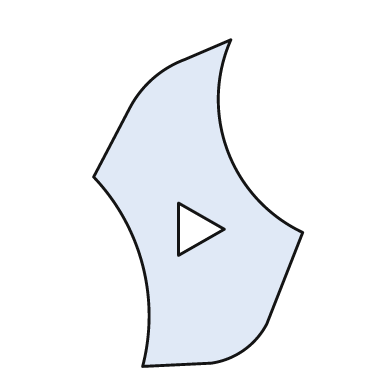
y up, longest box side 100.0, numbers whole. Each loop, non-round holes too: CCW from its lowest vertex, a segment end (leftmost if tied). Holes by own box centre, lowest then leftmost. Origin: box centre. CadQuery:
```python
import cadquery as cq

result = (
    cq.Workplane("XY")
    .moveTo(-17.0, -50.0)
    .lineTo(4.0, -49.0)
    .threePointArc((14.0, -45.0), (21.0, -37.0))
    .lineTo(32.0, -9.0)
    .threePointArc((9.0, 16.0), (10.0, 50.0))
    .lineTo(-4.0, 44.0)
    .threePointArc((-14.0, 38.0), (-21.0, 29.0))
    .lineTo(-32.0, 8.0)
    .threePointArc((-17.0, -19.0), (-17.0, -50.0))
    .close()
    .moveTo(-6.0, -16.0)
    .lineTo(8.0, -8.0)
    .lineTo(-6.0, 0.0)
    .close()
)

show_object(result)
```